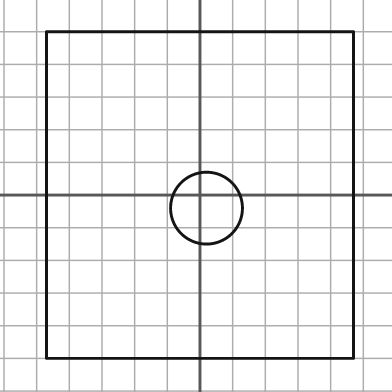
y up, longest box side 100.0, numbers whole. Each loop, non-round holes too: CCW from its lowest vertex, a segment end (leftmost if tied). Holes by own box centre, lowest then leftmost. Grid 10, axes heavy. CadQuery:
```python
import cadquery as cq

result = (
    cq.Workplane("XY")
    .moveTo(-47.0, -50.0)
    .lineTo(47.0, -50.0)
    .lineTo(47.0, 50.0)
    .lineTo(-47.0, 50.0)
    .close()
    .moveTo(2.0, -4.0)
    .circle(11.0)
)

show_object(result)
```